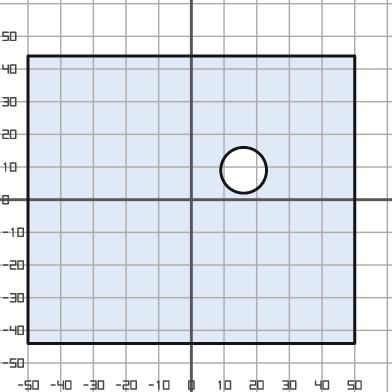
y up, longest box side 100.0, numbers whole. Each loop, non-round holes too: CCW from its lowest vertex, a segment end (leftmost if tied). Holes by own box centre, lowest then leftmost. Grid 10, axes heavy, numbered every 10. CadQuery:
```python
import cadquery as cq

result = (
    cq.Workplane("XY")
    .moveTo(-50.0, -44.0)
    .lineTo(50.0, -44.0)
    .lineTo(50.0, 44.0)
    .lineTo(-50.0, 44.0)
    .close()
    .moveTo(16.0, 9.0)
    .circle(7.0)
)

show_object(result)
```